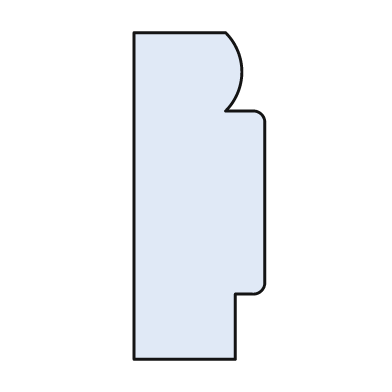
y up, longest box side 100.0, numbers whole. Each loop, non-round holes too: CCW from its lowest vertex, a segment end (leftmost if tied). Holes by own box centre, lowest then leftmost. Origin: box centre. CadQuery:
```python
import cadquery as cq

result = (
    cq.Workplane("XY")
    .moveTo(-20.0, -50.0)
    .lineTo(11.0, -50.0)
    .lineTo(11.0, -30.0)
    .lineTo(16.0, -30.0)
    .threePointArc((19.0, -29.0), (20.0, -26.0))
    .lineTo(20.0, 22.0)
    .threePointArc((19.0, 25.0), (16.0, 26.0))
    .lineTo(8.0, 26.0)
    .threePointArc((13.0, 38.0), (8.0, 50.0))
    .lineTo(-20.0, 50.0)
    .close()
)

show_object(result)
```